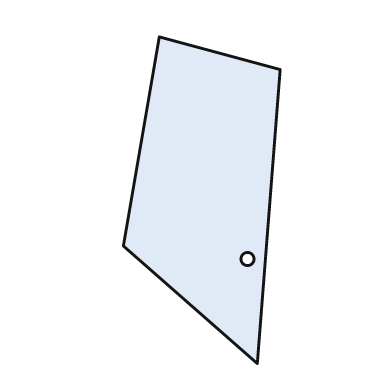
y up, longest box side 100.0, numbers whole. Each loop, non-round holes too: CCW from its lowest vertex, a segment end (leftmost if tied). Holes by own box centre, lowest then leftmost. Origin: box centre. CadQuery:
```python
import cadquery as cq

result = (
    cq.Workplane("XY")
    .moveTo(17.0, -50.0)
    .lineTo(24.0, 40.0)
    .lineTo(-13.0, 50.0)
    .lineTo(-24.0, -14.0)
    .close()
    .moveTo(14.0, -18.0)
    .circle(2.0)
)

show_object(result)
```